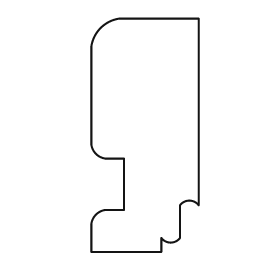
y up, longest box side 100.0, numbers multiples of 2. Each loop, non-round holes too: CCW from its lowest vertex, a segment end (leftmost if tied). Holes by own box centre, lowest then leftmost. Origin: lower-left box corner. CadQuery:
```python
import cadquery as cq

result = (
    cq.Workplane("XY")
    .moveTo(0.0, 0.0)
    .lineTo(30.0, 0.0)
    .lineTo(30.0, 6.0)
    .threePointArc((34.0, 4.0), (38.0, 6.0))
    .lineTo(38.0, 20.0)
    .threePointArc((42.0, 22.0), (46.0, 20.0))
    .lineTo(46.0, 100.0)
    .lineTo(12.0, 100.0)
    .threePointArc((4.0, 96.0), (0.0, 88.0))
    .lineTo(0.0, 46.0)
    .threePointArc((2.0, 42.0), (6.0, 40.0))
    .lineTo(14.0, 40.0)
    .lineTo(14.0, 18.0)
    .lineTo(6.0, 18.0)
    .threePointArc((2.0, 16.0), (0.0, 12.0))
    .close()
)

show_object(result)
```